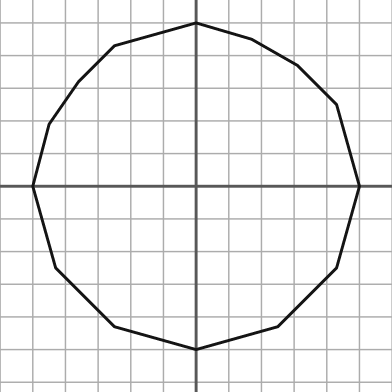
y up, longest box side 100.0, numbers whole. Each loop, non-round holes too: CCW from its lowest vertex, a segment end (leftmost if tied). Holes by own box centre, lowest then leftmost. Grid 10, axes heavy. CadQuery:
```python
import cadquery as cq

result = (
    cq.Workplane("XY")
    .moveTo(0.0, -50.0)
    .lineTo(25.0, -43.0)
    .lineTo(43.0, -25.0)
    .lineTo(50.0, 0.0)
    .lineTo(43.0, 25.0)
    .lineTo(31.0, 37.0)
    .lineTo(17.0, 45.0)
    .lineTo(0.0, 50.0)
    .lineTo(-25.0, 43.0)
    .lineTo(-36.0, 32.0)
    .lineTo(-45.0, 19.0)
    .lineTo(-50.0, 0.0)
    .lineTo(-43.0, -25.0)
    .lineTo(-25.0, -43.0)
    .close()
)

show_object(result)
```